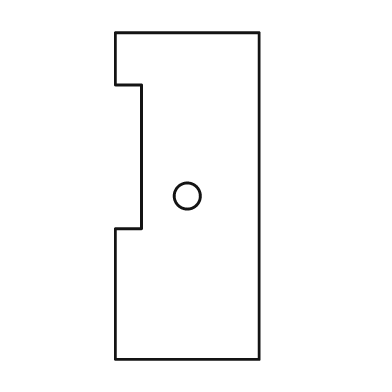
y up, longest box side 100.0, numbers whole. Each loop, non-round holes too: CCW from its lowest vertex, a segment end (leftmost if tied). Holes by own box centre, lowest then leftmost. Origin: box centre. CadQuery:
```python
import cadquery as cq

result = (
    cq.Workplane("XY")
    .moveTo(-22.0, -50.0)
    .lineTo(22.0, -50.0)
    .lineTo(22.0, 50.0)
    .lineTo(-22.0, 50.0)
    .lineTo(-22.0, 34.0)
    .lineTo(-14.0, 34.0)
    .lineTo(-14.0, -10.0)
    .lineTo(-22.0, -10.0)
    .close()
    .moveTo(0.0, 0.0)
    .circle(4.0)
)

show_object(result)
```